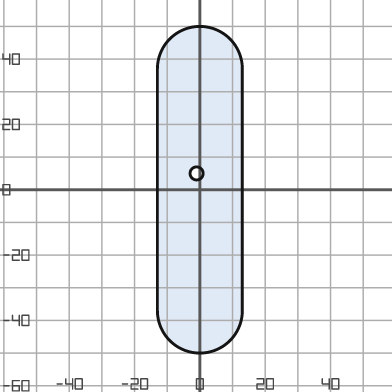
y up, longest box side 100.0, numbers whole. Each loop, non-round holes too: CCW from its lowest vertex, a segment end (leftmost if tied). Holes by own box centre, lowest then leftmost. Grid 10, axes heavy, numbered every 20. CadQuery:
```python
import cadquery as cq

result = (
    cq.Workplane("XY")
    .moveTo(-13.0, -37.0)
    .threePointArc((0.0, -50.0), (13.0, -37.0))
    .lineTo(13.0, 37.0)
    .threePointArc((0.0, 50.0), (-13.0, 37.0))
    .close()
    .moveTo(-1.0, 5.0)
    .circle(2.0)
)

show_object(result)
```